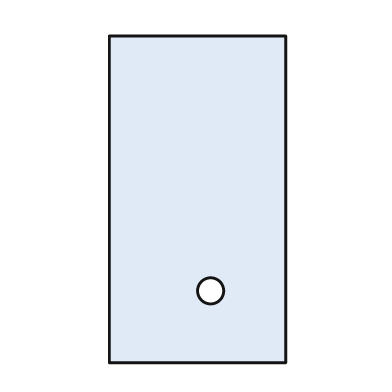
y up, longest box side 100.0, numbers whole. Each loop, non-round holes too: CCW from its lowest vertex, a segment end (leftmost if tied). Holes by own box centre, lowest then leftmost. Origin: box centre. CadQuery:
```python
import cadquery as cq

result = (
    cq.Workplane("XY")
    .moveTo(-27.0, -50.0)
    .lineTo(27.0, -50.0)
    .lineTo(27.0, 50.0)
    .lineTo(-27.0, 50.0)
    .close()
    .moveTo(4.0, -28.0)
    .circle(4.0)
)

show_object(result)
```